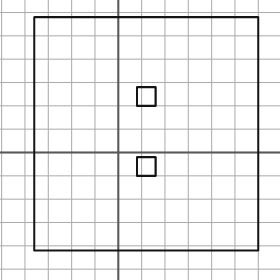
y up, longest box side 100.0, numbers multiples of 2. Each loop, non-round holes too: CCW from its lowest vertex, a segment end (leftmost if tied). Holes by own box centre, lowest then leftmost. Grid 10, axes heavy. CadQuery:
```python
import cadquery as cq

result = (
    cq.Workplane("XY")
    .moveTo(-36.0, -42.0)
    .lineTo(60.0, -42.0)
    .lineTo(60.0, 58.0)
    .lineTo(-36.0, 58.0)
    .close()
    .moveTo(8.0, -10.0)
    .lineTo(16.0, -10.0)
    .lineTo(16.0, -2.0)
    .lineTo(8.0, -2.0)
    .close()
    .moveTo(8.0, 20.0)
    .lineTo(16.0, 20.0)
    .lineTo(16.0, 28.0)
    .lineTo(8.0, 28.0)
    .close()
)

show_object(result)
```